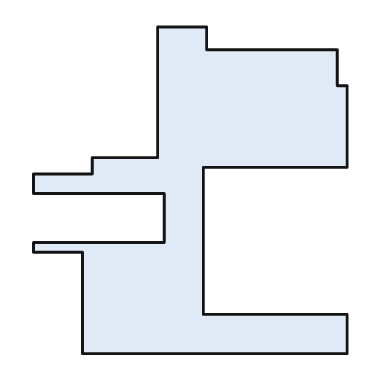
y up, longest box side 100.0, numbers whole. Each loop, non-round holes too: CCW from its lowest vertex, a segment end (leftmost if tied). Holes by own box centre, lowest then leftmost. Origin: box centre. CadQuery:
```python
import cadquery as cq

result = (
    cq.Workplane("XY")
    .moveTo(-33.0, -50.0)
    .lineTo(48.0, -50.0)
    .lineTo(48.0, -38.0)
    .lineTo(4.0, -38.0)
    .lineTo(4.0, 7.0)
    .lineTo(48.0, 7.0)
    .lineTo(48.0, 32.0)
    .lineTo(45.0, 32.0)
    .lineTo(45.0, 43.0)
    .lineTo(5.0, 43.0)
    .lineTo(5.0, 50.0)
    .lineTo(-10.0, 50.0)
    .lineTo(-10.0, 10.0)
    .lineTo(-30.0, 10.0)
    .lineTo(-30.0, 5.0)
    .lineTo(-48.0, 5.0)
    .lineTo(-48.0, -1.0)
    .lineTo(-8.0, -1.0)
    .lineTo(-8.0, -16.0)
    .lineTo(-48.0, -16.0)
    .lineTo(-48.0, -19.0)
    .lineTo(-33.0, -19.0)
    .close()
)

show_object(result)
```